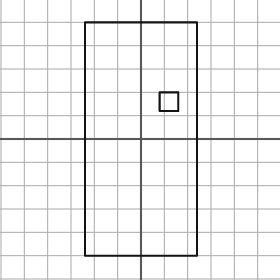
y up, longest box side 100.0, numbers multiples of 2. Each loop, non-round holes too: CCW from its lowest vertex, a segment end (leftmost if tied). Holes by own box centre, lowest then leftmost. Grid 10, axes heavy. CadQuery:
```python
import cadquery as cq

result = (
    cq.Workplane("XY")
    .moveTo(-24.0, -50.0)
    .lineTo(24.0, -50.0)
    .lineTo(24.0, 50.0)
    .lineTo(-24.0, 50.0)
    .close()
    .moveTo(8.0, 12.0)
    .lineTo(16.0, 12.0)
    .lineTo(16.0, 20.0)
    .lineTo(8.0, 20.0)
    .close()
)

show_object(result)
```